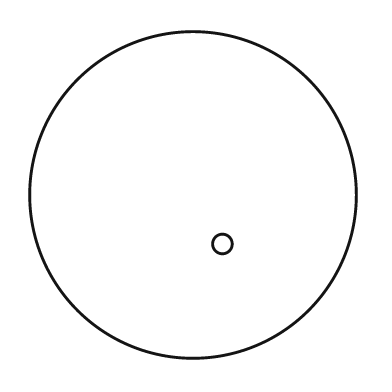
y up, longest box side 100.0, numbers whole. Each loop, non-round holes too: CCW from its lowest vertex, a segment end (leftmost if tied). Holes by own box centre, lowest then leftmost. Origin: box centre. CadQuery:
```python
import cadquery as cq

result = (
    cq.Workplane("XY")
    .moveTo(0.0, 0.0)
    .circle(50.0)
    .moveTo(9.0, -15.0)
    .circle(3.0)
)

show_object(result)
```